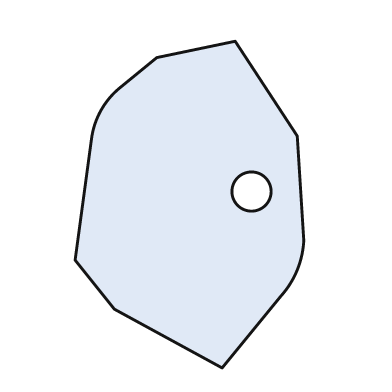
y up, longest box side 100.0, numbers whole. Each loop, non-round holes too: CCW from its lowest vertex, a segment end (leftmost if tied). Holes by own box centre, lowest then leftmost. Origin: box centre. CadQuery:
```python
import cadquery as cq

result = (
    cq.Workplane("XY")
    .moveTo(10.0, -50.0)
    .lineTo(28.0, -28.0)
    .threePointArc((33.0, -20.0), (35.0, -11.0))
    .lineTo(33.0, 21.0)
    .lineTo(14.0, 50.0)
    .lineTo(-10.0, 45.0)
    .lineTo(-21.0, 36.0)
    .threePointArc((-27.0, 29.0), (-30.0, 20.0))
    .lineTo(-35.0, -17.0)
    .lineTo(-23.0, -32.0)
    .close()
    .moveTo(19.0, 4.0)
    .circle(6.0)
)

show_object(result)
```